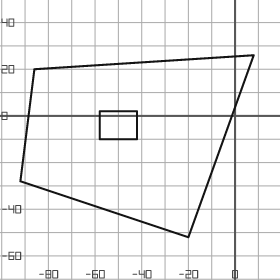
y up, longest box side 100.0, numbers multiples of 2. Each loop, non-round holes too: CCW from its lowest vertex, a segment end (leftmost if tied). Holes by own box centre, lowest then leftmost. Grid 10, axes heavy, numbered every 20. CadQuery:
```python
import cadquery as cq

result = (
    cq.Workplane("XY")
    .moveTo(-20.0, -52.0)
    .lineTo(8.0, 26.0)
    .lineTo(-86.0, 20.0)
    .lineTo(-92.0, -28.0)
    .close()
    .moveTo(-58.0, -10.0)
    .lineTo(-42.0, -10.0)
    .lineTo(-42.0, 2.0)
    .lineTo(-58.0, 2.0)
    .close()
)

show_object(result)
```